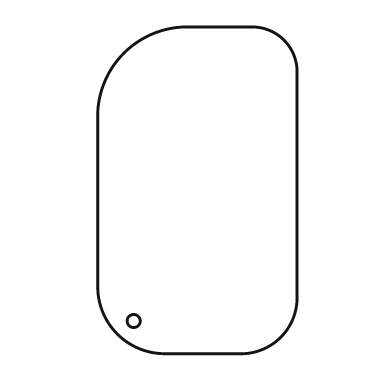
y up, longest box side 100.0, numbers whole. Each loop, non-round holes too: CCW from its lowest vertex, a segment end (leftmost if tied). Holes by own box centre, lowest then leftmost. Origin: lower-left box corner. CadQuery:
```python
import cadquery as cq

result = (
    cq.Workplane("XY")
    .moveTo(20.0, 0.0)
    .lineTo(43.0, 0.0)
    .threePointArc((56.0, 5.0), (61.0, 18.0))
    .lineTo(61.0, 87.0)
    .threePointArc((57.0, 96.0), (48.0, 100.0))
    .lineTo(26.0, 100.0)
    .threePointArc((8.0, 92.0), (0.0, 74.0))
    .lineTo(0.0, 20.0)
    .threePointArc((6.0, 6.0), (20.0, 0.0))
    .close()
    .moveTo(11.0, 10.0)
    .circle(2.0)
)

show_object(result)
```